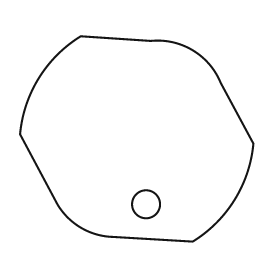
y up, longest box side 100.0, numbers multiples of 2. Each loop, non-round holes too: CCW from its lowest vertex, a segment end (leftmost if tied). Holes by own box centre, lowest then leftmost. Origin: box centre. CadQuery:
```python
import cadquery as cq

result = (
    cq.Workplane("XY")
    .moveTo(24.0, -44.0)
    .threePointArc((42.0, -26.0), (50.0, -2.0))
    .lineTo(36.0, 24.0)
    .threePointArc((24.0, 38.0), (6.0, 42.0))
    .lineTo(-24.0, 44.0)
    .threePointArc((-42.0, 26.0), (-50.0, 2.0))
    .lineTo(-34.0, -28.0)
    .threePointArc((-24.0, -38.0), (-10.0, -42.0))
    .close()
    .moveTo(4.0, -28.0)
    .circle(6.0)
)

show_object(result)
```